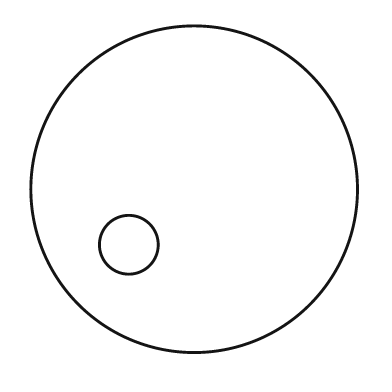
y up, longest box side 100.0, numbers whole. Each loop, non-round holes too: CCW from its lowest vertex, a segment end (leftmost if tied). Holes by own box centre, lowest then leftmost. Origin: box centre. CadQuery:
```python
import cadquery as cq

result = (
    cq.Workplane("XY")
    .moveTo(0.0, 0.0)
    .circle(50.0)
    .moveTo(-20.0, -17.0)
    .circle(9.0)
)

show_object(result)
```